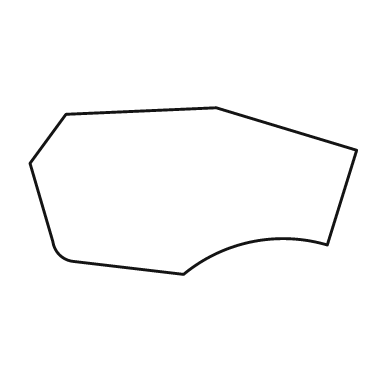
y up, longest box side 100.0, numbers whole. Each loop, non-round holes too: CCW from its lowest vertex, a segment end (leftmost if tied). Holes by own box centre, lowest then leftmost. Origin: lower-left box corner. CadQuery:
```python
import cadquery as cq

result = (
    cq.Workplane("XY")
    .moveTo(47.0, 0.0)
    .threePointArc((68.0, 10.0), (91.0, 9.0))
    .lineTo(100.0, 38.0)
    .lineTo(57.0, 51.0)
    .lineTo(11.0, 49.0)
    .lineTo(0.0, 34.0)
    .lineTo(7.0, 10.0)
    .threePointArc((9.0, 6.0), (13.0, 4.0))
    .close()
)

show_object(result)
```